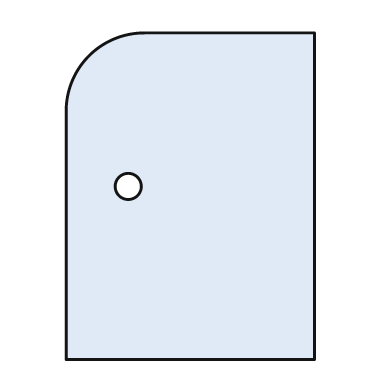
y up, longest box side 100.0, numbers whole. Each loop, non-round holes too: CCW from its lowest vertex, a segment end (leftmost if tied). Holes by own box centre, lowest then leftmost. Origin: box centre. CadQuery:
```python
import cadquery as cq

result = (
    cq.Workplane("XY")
    .moveTo(-38.0, -50.0)
    .lineTo(38.0, -50.0)
    .lineTo(38.0, 50.0)
    .lineTo(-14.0, 50.0)
    .threePointArc((-31.0, 43.0), (-38.0, 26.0))
    .close()
    .moveTo(-19.0, 3.0)
    .circle(4.0)
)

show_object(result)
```